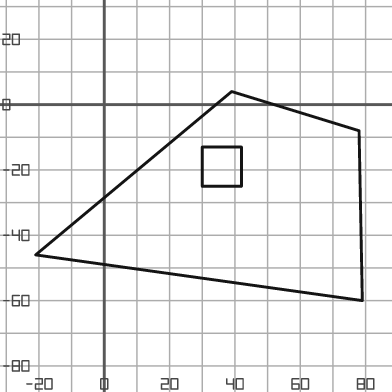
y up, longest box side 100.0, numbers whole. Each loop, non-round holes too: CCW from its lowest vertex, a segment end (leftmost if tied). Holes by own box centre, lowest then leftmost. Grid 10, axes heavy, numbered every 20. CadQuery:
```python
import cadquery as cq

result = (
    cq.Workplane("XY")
    .moveTo(79.0, -60.0)
    .lineTo(78.0, -8.0)
    .lineTo(39.0, 4.0)
    .lineTo(-21.0, -46.0)
    .close()
    .moveTo(30.0, -25.0)
    .lineTo(42.0, -25.0)
    .lineTo(42.0, -13.0)
    .lineTo(30.0, -13.0)
    .close()
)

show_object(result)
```